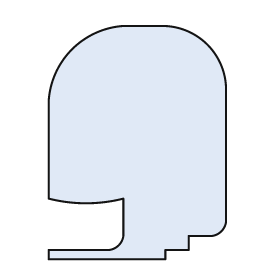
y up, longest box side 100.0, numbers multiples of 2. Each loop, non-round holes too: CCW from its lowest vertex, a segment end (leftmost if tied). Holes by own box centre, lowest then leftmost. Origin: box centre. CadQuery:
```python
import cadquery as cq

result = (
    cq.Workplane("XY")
    .moveTo(-38.0, -50.0)
    .lineTo(12.0, -50.0)
    .lineTo(12.0, -46.0)
    .lineTo(22.0, -46.0)
    .lineTo(22.0, -40.0)
    .lineTo(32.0, -40.0)
    .threePointArc((36.0, -38.0), (38.0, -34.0))
    .lineTo(38.0, 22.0)
    .threePointArc((30.0, 42.0), (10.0, 50.0))
    .lineTo(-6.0, 50.0)
    .threePointArc((-28.0, 40.0), (-38.0, 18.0))
    .lineTo(-38.0, -24.0)
    .threePointArc((-22.0, -26.0), (-6.0, -24.0))
    .lineTo(-6.0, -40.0)
    .threePointArc((-8.0, -44.0), (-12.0, -46.0))
    .lineTo(-38.0, -46.0)
    .close()
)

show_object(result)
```